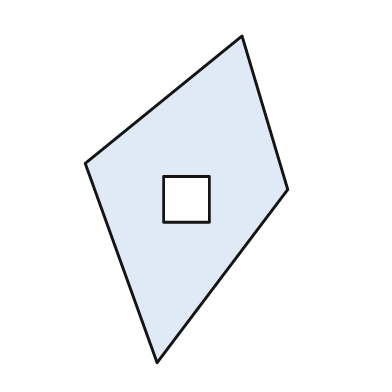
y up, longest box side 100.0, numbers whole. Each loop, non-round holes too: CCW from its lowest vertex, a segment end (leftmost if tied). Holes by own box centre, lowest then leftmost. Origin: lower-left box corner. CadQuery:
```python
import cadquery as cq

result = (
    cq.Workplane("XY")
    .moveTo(22.0, 0.0)
    .lineTo(62.0, 53.0)
    .lineTo(48.0, 100.0)
    .lineTo(0.0, 61.0)
    .close()
    .moveTo(24.0, 43.0)
    .lineTo(38.0, 43.0)
    .lineTo(38.0, 57.0)
    .lineTo(24.0, 57.0)
    .close()
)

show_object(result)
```